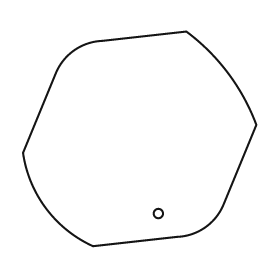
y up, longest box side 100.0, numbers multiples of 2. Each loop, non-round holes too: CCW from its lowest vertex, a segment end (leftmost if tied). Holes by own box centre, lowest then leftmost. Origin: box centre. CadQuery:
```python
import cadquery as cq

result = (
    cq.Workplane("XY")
    .moveTo(-20.0, -46.0)
    .lineTo(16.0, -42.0)
    .threePointArc((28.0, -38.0), (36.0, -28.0))
    .lineTo(50.0, 6.0)
    .threePointArc((38.0, 28.0), (20.0, 46.0))
    .lineTo(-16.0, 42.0)
    .threePointArc((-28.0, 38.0), (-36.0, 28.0))
    .lineTo(-50.0, -6.0)
    .threePointArc((-40.0, -30.0), (-20.0, -46.0))
    .close()
    .moveTo(8.0, -32.0)
    .circle(2.0)
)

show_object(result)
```